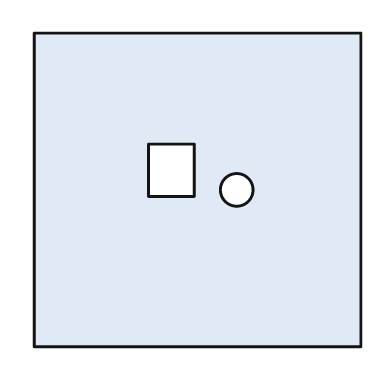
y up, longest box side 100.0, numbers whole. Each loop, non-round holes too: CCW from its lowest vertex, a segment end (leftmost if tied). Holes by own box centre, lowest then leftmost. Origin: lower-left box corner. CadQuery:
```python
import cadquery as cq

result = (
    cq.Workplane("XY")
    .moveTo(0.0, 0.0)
    .lineTo(100.0, 0.0)
    .lineTo(100.0, 96.0)
    .lineTo(0.0, 96.0)
    .close()
    .moveTo(62.0, 48.0)
    .circle(5.0)
    .moveTo(35.0, 46.0)
    .lineTo(49.0, 46.0)
    .lineTo(49.0, 62.0)
    .lineTo(35.0, 62.0)
    .close()
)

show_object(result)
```